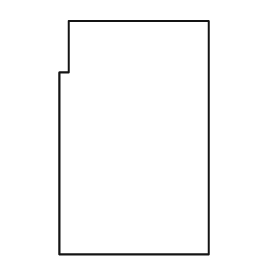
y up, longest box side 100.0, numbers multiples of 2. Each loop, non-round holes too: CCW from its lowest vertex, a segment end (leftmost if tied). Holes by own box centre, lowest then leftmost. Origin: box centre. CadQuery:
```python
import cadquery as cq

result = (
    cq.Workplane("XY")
    .moveTo(-32.0, -50.0)
    .lineTo(32.0, -50.0)
    .lineTo(32.0, 50.0)
    .lineTo(-28.0, 50.0)
    .lineTo(-28.0, 28.0)
    .lineTo(-32.0, 28.0)
    .close()
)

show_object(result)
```